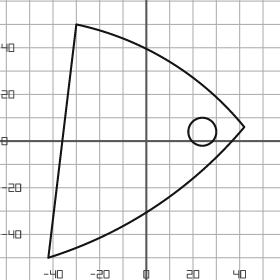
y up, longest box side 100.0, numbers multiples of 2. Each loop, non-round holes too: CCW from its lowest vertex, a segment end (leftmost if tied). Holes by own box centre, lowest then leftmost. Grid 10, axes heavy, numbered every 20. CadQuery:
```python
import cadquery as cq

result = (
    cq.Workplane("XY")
    .moveTo(-42.0, -50.0)
    .threePointArc((4.0, -28.0), (42.0, 6.0))
    .threePointArc((10.0, 34.0), (-30.0, 50.0))
    .close()
    .moveTo(24.0, 4.0)
    .circle(6.0)
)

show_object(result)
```